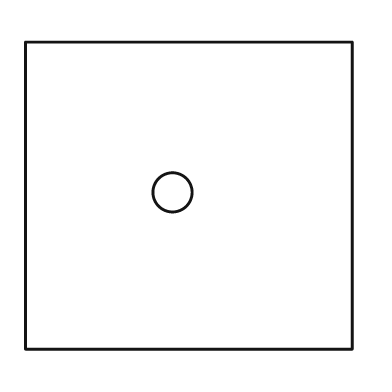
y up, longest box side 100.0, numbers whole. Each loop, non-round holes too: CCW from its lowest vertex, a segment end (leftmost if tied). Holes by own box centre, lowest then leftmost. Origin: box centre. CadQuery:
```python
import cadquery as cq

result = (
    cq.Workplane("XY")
    .moveTo(-50.0, -47.0)
    .lineTo(50.0, -47.0)
    .lineTo(50.0, 47.0)
    .lineTo(-50.0, 47.0)
    .close()
    .moveTo(-5.0, 1.0)
    .circle(6.0)
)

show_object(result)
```